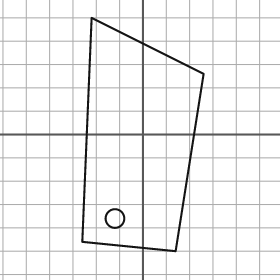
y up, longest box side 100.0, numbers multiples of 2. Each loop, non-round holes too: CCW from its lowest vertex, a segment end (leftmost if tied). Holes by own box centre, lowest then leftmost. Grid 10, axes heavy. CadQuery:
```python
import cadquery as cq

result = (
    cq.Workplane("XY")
    .moveTo(14.0, -50.0)
    .lineTo(26.0, 26.0)
    .lineTo(-22.0, 50.0)
    .lineTo(-26.0, -46.0)
    .close()
    .moveTo(-12.0, -36.0)
    .circle(4.0)
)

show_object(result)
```